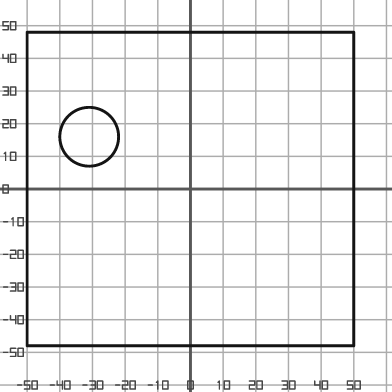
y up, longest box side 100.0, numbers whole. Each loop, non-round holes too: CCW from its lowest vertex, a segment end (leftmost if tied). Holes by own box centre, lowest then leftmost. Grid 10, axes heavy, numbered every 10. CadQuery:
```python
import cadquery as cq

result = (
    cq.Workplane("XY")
    .moveTo(-50.0, -48.0)
    .lineTo(50.0, -48.0)
    .lineTo(50.0, 48.0)
    .lineTo(-50.0, 48.0)
    .close()
    .moveTo(-31.0, 16.0)
    .circle(9.0)
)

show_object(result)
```